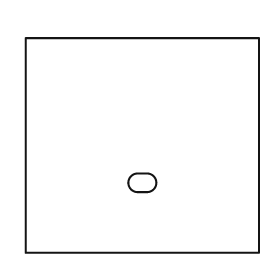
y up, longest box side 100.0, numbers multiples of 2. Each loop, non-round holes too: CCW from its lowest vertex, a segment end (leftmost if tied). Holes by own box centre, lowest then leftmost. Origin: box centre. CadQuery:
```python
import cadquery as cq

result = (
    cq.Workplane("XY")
    .moveTo(-50.0, -46.0)
    .lineTo(50.0, -46.0)
    .lineTo(50.0, 46.0)
    .lineTo(-50.0, 46.0)
    .close()
    .moveTo(-2.0, -20.0)
    .lineTo(2.0, -20.0)
    .threePointArc((6.0, -16.0), (2.0, -12.0))
    .lineTo(-2.0, -12.0)
    .threePointArc((-6.0, -16.0), (-2.0, -20.0))
    .close()
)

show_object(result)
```